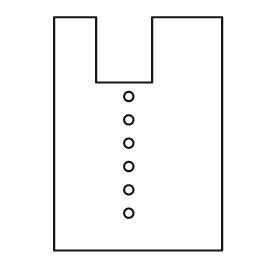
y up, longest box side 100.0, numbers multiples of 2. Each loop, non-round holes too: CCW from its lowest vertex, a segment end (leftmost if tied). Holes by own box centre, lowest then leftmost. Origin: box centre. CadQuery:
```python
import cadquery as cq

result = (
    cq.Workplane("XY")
    .moveTo(-36.0, -50.0)
    .lineTo(36.0, -50.0)
    .lineTo(36.0, 50.0)
    .lineTo(6.0, 50.0)
    .lineTo(6.0, 22.0)
    .lineTo(-18.0, 22.0)
    .lineTo(-18.0, 50.0)
    .lineTo(-36.0, 50.0)
    .close()
    .moveTo(-4.0, -34.0)
    .circle(2.0)
    .moveTo(-4.0, -24.0)
    .circle(2.0)
    .moveTo(-4.0, -14.0)
    .circle(2.0)
    .moveTo(-4.0, -4.0)
    .circle(2.0)
    .moveTo(-4.0, 6.0)
    .circle(2.0)
    .moveTo(-4.0, 16.0)
    .circle(2.0)
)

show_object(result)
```